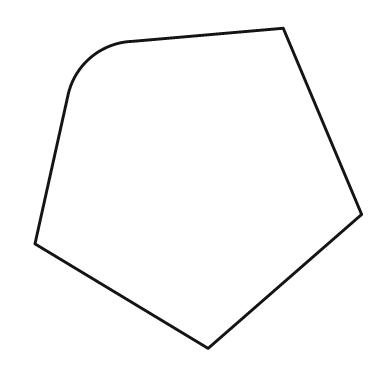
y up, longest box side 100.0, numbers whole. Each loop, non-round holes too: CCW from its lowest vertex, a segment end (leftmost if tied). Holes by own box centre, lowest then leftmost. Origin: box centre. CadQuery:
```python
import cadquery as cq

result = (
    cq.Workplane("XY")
    .moveTo(3.0, -49.0)
    .lineTo(50.0, -8.0)
    .lineTo(26.0, 49.0)
    .lineTo(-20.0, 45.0)
    .threePointArc((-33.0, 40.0), (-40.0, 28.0))
    .lineTo(-50.0, -17.0)
    .close()
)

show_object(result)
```